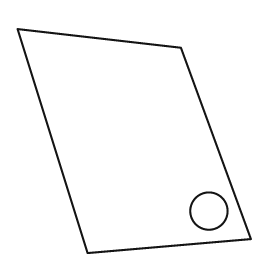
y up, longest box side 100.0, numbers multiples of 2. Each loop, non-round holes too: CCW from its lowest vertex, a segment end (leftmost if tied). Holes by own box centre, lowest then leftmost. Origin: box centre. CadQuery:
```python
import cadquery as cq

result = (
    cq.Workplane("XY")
    .moveTo(-20.0, -48.0)
    .lineTo(50.0, -42.0)
    .lineTo(20.0, 40.0)
    .lineTo(-50.0, 48.0)
    .close()
    .moveTo(32.0, -30.0)
    .circle(8.0)
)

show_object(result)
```